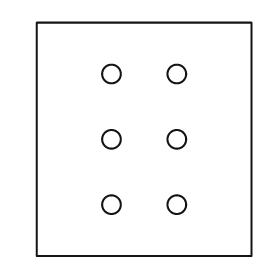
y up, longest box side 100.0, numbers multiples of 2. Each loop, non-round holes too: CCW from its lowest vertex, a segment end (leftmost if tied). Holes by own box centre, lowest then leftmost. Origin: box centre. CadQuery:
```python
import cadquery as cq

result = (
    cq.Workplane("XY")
    .moveTo(-46.0, -50.0)
    .lineTo(46.0, -50.0)
    .lineTo(46.0, 50.0)
    .lineTo(-46.0, 50.0)
    .close()
    .moveTo(-14.0, -28.0)
    .circle(4.0)
    .moveTo(14.0, -28.0)
    .circle(4.0)
    .moveTo(-14.0, 0.0)
    .circle(4.0)
    .moveTo(14.0, 0.0)
    .circle(4.0)
    .moveTo(-14.0, 28.0)
    .circle(4.0)
    .moveTo(14.0, 28.0)
    .circle(4.0)
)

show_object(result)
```